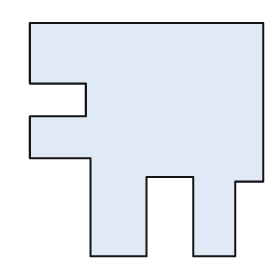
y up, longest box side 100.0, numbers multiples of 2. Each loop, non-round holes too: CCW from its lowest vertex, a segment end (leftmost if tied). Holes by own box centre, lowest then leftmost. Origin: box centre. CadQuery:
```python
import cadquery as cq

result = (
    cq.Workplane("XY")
    .moveTo(-24.0, -50.0)
    .lineTo(0.0, -50.0)
    .lineTo(0.0, -16.0)
    .lineTo(20.0, -16.0)
    .lineTo(20.0, -50.0)
    .lineTo(38.0, -50.0)
    .lineTo(38.0, -18.0)
    .lineTo(50.0, -18.0)
    .lineTo(50.0, 50.0)
    .lineTo(-50.0, 50.0)
    .lineTo(-50.0, 24.0)
    .lineTo(-26.0, 24.0)
    .lineTo(-26.0, 10.0)
    .lineTo(-50.0, 10.0)
    .lineTo(-50.0, -8.0)
    .lineTo(-24.0, -8.0)
    .close()
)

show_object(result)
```